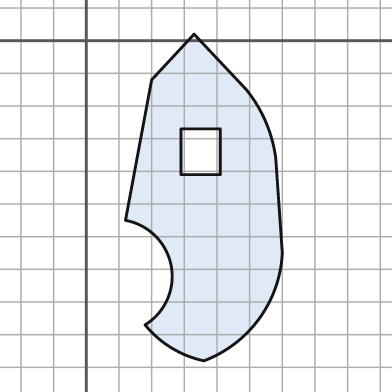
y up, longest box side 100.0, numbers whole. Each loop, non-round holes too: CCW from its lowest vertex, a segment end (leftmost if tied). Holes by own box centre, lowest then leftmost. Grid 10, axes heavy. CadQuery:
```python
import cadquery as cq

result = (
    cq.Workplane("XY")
    .moveTo(36.0, -98.0)
    .threePointArc((53.0, -85.0), (60.0, -65.0))
    .lineTo(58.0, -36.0)
    .threePointArc((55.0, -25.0), (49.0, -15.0))
    .lineTo(33.0, 2.0)
    .lineTo(20.0, -12.0)
    .lineTo(12.0, -55.0)
    .threePointArc((26.0, -69.0), (18.0, -87.0))
    .threePointArc((26.0, -94.0), (36.0, -98.0))
    .close()
    .moveTo(29.0, -41.0)
    .lineTo(41.0, -41.0)
    .lineTo(41.0, -27.0)
    .lineTo(29.0, -27.0)
    .close()
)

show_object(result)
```